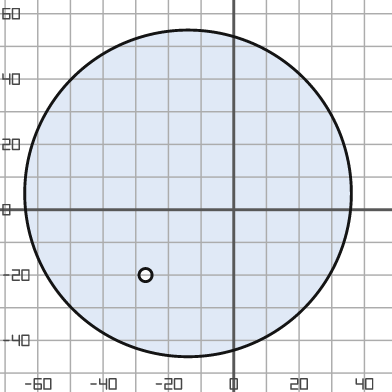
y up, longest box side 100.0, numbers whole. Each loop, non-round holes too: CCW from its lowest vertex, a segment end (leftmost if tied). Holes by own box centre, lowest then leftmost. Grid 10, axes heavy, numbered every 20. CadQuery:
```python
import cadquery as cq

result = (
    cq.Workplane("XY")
    .moveTo(-14.0, 5.0)
    .circle(50.0)
    .moveTo(-27.0, -20.0)
    .circle(2.0)
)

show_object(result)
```